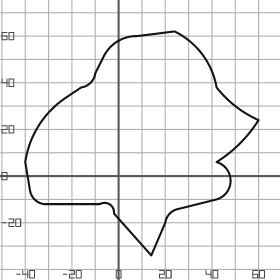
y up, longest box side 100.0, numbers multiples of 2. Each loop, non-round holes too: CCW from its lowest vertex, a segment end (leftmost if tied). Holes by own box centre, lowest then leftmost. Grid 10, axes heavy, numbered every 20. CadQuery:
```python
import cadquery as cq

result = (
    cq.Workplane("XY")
    .moveTo(14.0, -34.0)
    .lineTo(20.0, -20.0)
    .threePointArc((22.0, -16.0), (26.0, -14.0))
    .lineTo(42.0, -10.0)
    .threePointArc((48.0, -2.0), (42.0, 6.0))
    .threePointArc((52.0, 14.0), (60.0, 24.0))
    .threePointArc((50.0, 30.0), (42.0, 38.0))
    .threePointArc((36.0, 52.0), (24.0, 62.0))
    .lineTo(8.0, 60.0)
    .threePointArc((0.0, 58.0), (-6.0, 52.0))
    .lineTo(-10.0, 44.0)
    .threePointArc((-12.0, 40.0), (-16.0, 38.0))
    .lineTo(-22.0, 34.0)
    .threePointArc((-34.0, 22.0), (-40.0, 6.0))
    .lineTo(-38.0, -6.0)
    .threePointArc((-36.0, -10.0), (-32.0, -12.0))
    .lineTo(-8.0, -12.0)
    .threePointArc((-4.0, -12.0), (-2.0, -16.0))
    .close()
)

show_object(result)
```